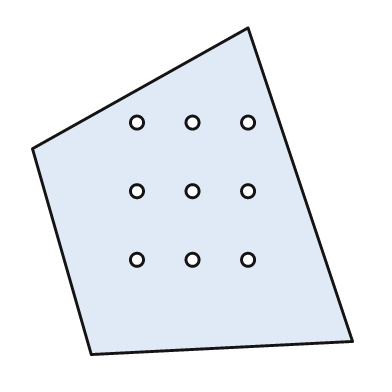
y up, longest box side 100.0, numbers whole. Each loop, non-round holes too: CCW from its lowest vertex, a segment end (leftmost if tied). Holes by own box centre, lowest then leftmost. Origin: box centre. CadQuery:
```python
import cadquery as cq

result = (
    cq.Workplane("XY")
    .moveTo(-31.0, -50.0)
    .lineTo(49.0, -46.0)
    .lineTo(17.0, 50.0)
    .lineTo(-49.0, 13.0)
    .close()
    .moveTo(-17.0, -21.0)
    .circle(2.0)
    .moveTo(0.0, -21.0)
    .circle(2.0)
    .moveTo(17.0, -21.0)
    .circle(2.0)
    .moveTo(-17.0, 0.0)
    .circle(2.0)
    .moveTo(0.0, 0.0)
    .circle(2.0)
    .moveTo(17.0, 0.0)
    .circle(2.0)
    .moveTo(-17.0, 21.0)
    .circle(2.0)
    .moveTo(0.0, 21.0)
    .circle(2.0)
    .moveTo(17.0, 21.0)
    .circle(2.0)
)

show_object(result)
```